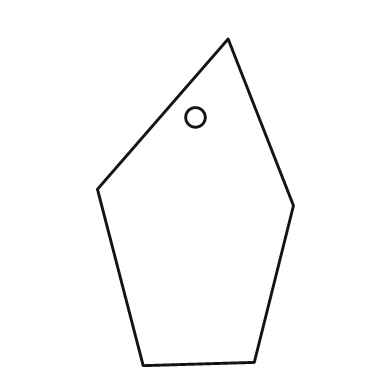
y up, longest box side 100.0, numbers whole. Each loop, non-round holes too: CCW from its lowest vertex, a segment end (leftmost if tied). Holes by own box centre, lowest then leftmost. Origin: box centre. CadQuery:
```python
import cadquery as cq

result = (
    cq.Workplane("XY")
    .moveTo(-16.0, -50.0)
    .lineTo(18.0, -49.0)
    .lineTo(30.0, -1.0)
    .lineTo(10.0, 50.0)
    .lineTo(-30.0, 4.0)
    .close()
    .moveTo(0.0, 26.0)
    .circle(3.0)
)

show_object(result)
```